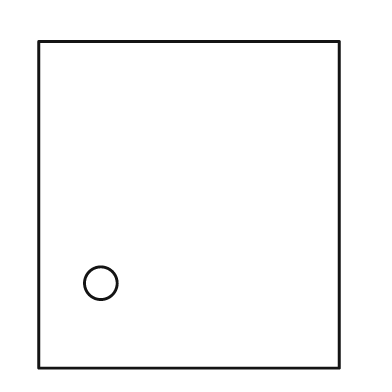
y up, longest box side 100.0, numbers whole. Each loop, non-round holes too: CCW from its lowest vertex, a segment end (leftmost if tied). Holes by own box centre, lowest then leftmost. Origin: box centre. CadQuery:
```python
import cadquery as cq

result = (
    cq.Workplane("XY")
    .moveTo(-46.0, -50.0)
    .lineTo(46.0, -50.0)
    .lineTo(46.0, 50.0)
    .lineTo(-46.0, 50.0)
    .close()
    .moveTo(-27.0, -24.0)
    .circle(5.0)
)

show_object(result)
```